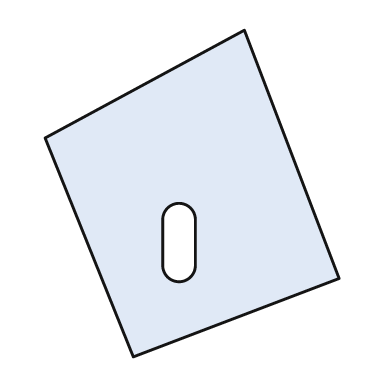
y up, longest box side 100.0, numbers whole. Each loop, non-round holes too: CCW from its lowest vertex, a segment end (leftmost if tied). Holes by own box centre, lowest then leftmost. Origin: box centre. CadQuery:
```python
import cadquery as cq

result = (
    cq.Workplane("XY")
    .moveTo(-18.0, -50.0)
    .lineTo(45.0, -26.0)
    .lineTo(16.0, 50.0)
    .lineTo(-45.0, 17.0)
    .close()
    .moveTo(-9.0, -22.0)
    .threePointArc((-4.0, -27.0), (1.0, -22.0))
    .lineTo(1.0, -8.0)
    .threePointArc((-4.0, -3.0), (-9.0, -8.0))
    .close()
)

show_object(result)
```